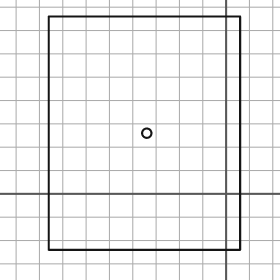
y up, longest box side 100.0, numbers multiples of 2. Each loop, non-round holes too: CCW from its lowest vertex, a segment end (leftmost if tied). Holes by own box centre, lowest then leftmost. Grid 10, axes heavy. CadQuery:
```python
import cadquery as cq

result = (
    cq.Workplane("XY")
    .moveTo(-76.0, -24.0)
    .lineTo(6.0, -24.0)
    .lineTo(6.0, 76.0)
    .lineTo(-76.0, 76.0)
    .close()
    .moveTo(-34.0, 26.0)
    .circle(2.0)
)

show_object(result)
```